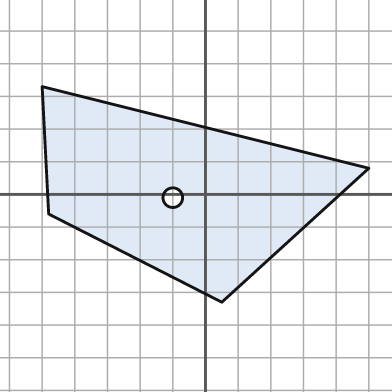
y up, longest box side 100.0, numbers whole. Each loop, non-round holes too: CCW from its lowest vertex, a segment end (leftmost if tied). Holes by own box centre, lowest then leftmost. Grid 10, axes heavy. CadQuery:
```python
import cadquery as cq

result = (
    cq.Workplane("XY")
    .moveTo(5.0, -33.0)
    .lineTo(50.0, 8.0)
    .lineTo(-50.0, 33.0)
    .lineTo(-48.0, -6.0)
    .close()
    .moveTo(-10.0, -1.0)
    .circle(3.0)
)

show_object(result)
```